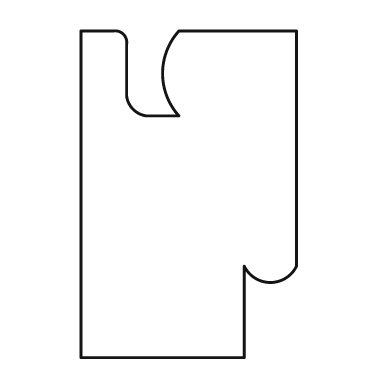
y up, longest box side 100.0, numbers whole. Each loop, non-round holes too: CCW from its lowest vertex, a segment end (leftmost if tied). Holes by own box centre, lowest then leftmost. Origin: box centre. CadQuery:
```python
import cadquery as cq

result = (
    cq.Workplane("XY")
    .moveTo(-33.0, -50.0)
    .lineTo(17.0, -50.0)
    .lineTo(17.0, -22.0)
    .threePointArc((25.0, -27.0), (33.0, -22.0))
    .lineTo(33.0, 50.0)
    .lineTo(-3.0, 50.0)
    .threePointArc((-8.0, 37.0), (-3.0, 24.0))
    .lineTo(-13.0, 24.0)
    .threePointArc((-17.0, 26.0), (-19.0, 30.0))
    .lineTo(-19.0, 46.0)
    .threePointArc((-20.0, 49.0), (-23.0, 50.0))
    .lineTo(-33.0, 50.0)
    .close()
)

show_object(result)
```